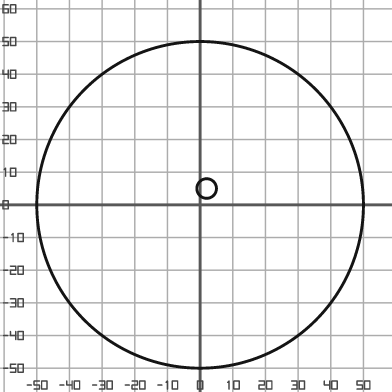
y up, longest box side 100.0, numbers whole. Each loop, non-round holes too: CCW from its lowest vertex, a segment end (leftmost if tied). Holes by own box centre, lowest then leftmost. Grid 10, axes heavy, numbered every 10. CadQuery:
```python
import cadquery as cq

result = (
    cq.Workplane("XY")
    .moveTo(0.0, 0.0)
    .circle(50.0)
    .moveTo(2.0, 5.0)
    .circle(3.0)
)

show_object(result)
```